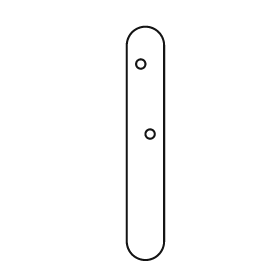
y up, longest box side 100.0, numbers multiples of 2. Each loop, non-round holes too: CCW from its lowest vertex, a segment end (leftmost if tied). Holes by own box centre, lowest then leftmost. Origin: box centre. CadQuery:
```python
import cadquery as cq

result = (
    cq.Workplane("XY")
    .moveTo(-8.0, -42.0)
    .threePointArc((0.0, -50.0), (8.0, -42.0))
    .lineTo(8.0, 42.0)
    .threePointArc((0.0, 50.0), (-8.0, 42.0))
    .close()
    .moveTo(2.0, 4.0)
    .circle(2.0)
    .moveTo(-2.0, 34.0)
    .circle(2.0)
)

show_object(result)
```